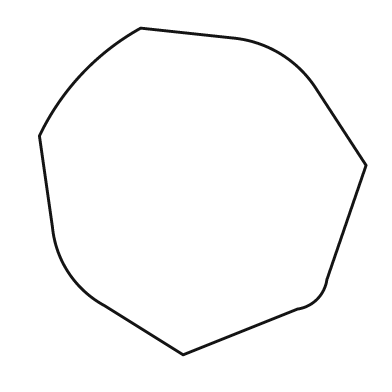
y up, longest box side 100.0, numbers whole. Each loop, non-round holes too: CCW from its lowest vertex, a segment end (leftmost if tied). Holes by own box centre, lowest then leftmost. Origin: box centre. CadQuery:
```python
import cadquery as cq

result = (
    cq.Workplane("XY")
    .moveTo(-6.0, -50.0)
    .lineTo(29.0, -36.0)
    .threePointArc((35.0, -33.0), (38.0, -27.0))
    .lineTo(50.0, 8.0)
    .lineTo(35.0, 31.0)
    .threePointArc((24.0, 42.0), (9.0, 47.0))
    .lineTo(-19.0, 50.0)
    .threePointArc((-37.0, 36.0), (-50.0, 17.0))
    .lineTo(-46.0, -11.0)
    .threePointArc((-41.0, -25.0), (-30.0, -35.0))
    .close()
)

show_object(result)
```